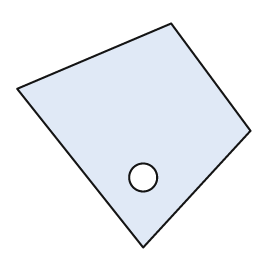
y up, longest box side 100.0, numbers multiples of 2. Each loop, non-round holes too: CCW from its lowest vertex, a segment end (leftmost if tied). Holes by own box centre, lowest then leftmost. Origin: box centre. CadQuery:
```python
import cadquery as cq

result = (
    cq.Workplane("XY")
    .moveTo(4.0, -48.0)
    .lineTo(50.0, 2.0)
    .lineTo(16.0, 48.0)
    .lineTo(-50.0, 20.0)
    .close()
    .moveTo(4.0, -18.0)
    .circle(6.0)
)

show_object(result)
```